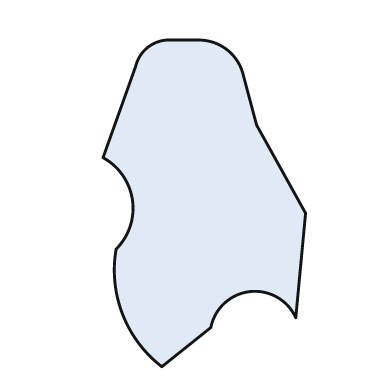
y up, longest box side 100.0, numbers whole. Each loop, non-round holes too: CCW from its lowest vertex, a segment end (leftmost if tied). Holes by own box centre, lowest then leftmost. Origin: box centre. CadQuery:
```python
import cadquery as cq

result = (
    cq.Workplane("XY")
    .moveTo(-13.0, -50.0)
    .lineTo(2.0, -38.0)
    .threePointArc((14.0, -27.0), (28.0, -35.0))
    .lineTo(31.0, -3.0)
    .lineTo(16.0, 24.0)
    .lineTo(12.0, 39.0)
    .threePointArc((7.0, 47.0), (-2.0, 50.0))
    .lineTo(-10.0, 50.0)
    .threePointArc((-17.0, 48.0), (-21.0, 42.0))
    .lineTo(-31.0, 14.0)
    .threePointArc((-22.0, 1.0), (-27.0, -14.0))
    .threePointArc((-25.0, -34.0), (-13.0, -50.0))
    .close()
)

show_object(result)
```